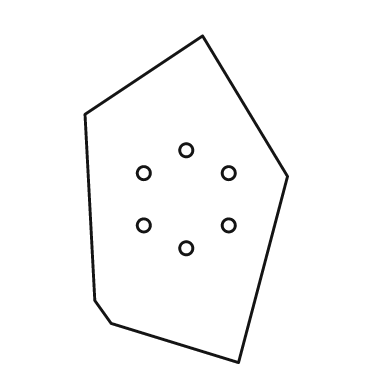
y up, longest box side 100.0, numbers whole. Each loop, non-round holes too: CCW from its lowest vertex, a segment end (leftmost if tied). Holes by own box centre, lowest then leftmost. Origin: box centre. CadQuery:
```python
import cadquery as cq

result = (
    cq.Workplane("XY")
    .moveTo(16.0, -50.0)
    .lineTo(31.0, 7.0)
    .lineTo(5.0, 50.0)
    .lineTo(-31.0, 26.0)
    .lineTo(-28.0, -31.0)
    .lineTo(-23.0, -38.0)
    .close()
    .moveTo(0.0, -15.0)
    .circle(2.0)
    .moveTo(-13.0, -8.0)
    .circle(2.0)
    .moveTo(13.0, -8.0)
    .circle(2.0)
    .moveTo(-13.0, 8.0)
    .circle(2.0)
    .moveTo(13.0, 8.0)
    .circle(2.0)
    .moveTo(0.0, 15.0)
    .circle(2.0)
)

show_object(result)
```